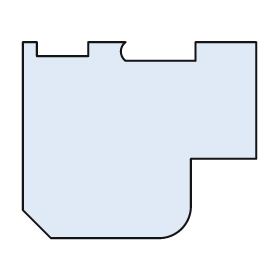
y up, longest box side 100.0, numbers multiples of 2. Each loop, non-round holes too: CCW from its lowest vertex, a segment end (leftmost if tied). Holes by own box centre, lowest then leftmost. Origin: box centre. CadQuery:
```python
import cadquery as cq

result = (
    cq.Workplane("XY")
    .moveTo(-38.0, -42.0)
    .lineTo(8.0, -42.0)
    .threePointArc((18.0, -38.0), (22.0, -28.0))
    .lineTo(22.0, -8.0)
    .lineTo(50.0, -8.0)
    .lineTo(50.0, 42.0)
    .lineTo(24.0, 42.0)
    .lineTo(24.0, 34.0)
    .lineTo(-6.0, 34.0)
    .threePointArc((-8.0, 38.0), (-6.0, 42.0))
    .lineTo(-22.0, 42.0)
    .lineTo(-22.0, 36.0)
    .lineTo(-44.0, 36.0)
    .lineTo(-44.0, 42.0)
    .lineTo(-50.0, 42.0)
    .lineTo(-50.0, -30.0)
    .close()
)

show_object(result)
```